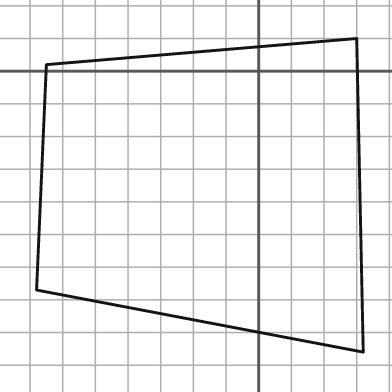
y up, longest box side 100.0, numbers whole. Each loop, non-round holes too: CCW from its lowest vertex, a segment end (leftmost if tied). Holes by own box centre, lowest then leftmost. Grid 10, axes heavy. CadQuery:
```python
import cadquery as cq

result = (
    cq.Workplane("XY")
    .moveTo(32.0, -86.0)
    .lineTo(30.0, 10.0)
    .lineTo(-65.0, 2.0)
    .lineTo(-68.0, -67.0)
    .close()
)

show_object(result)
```